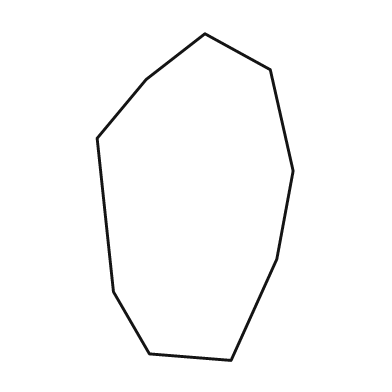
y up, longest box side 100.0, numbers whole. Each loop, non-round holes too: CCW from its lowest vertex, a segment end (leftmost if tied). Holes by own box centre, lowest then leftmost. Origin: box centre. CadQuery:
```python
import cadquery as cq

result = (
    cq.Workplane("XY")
    .moveTo(11.0, -50.0)
    .lineTo(25.0, -19.0)
    .lineTo(30.0, 8.0)
    .lineTo(23.0, 39.0)
    .lineTo(3.0, 50.0)
    .lineTo(-15.0, 36.0)
    .lineTo(-30.0, 18.0)
    .lineTo(-25.0, -29.0)
    .lineTo(-14.0, -48.0)
    .close()
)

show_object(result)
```